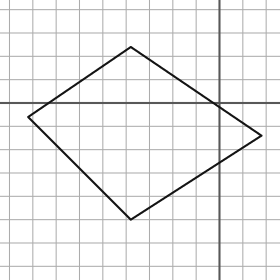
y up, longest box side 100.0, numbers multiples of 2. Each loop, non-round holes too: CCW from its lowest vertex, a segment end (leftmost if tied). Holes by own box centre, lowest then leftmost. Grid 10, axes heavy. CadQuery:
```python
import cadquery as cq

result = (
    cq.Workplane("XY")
    .moveTo(-38.0, -50.0)
    .lineTo(18.0, -14.0)
    .lineTo(-38.0, 24.0)
    .lineTo(-82.0, -6.0)
    .close()
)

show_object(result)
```